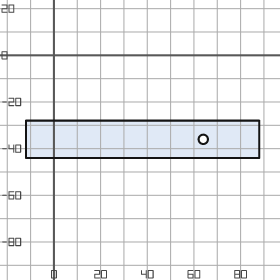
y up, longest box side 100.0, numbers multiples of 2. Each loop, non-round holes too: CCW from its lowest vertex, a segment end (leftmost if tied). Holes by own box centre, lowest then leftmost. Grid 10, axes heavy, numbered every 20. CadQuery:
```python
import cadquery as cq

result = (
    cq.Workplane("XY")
    .moveTo(-12.0, -44.0)
    .lineTo(88.0, -44.0)
    .lineTo(88.0, -28.0)
    .lineTo(-12.0, -28.0)
    .close()
    .moveTo(64.0, -36.0)
    .circle(2.0)
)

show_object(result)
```